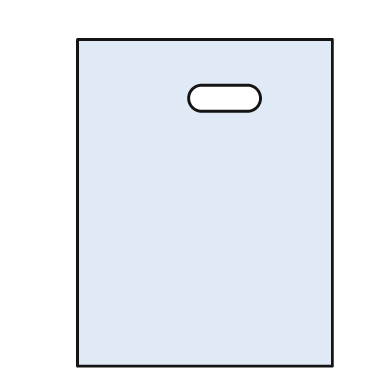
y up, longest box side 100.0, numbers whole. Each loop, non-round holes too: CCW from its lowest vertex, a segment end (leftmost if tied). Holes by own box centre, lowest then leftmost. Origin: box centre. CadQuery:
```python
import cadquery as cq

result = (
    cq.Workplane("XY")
    .moveTo(-39.0, -50.0)
    .lineTo(39.0, -50.0)
    .lineTo(39.0, 50.0)
    .lineTo(-39.0, 50.0)
    .close()
    .moveTo(-1.0, 28.0)
    .lineTo(13.0, 28.0)
    .threePointArc((17.0, 32.0), (13.0, 36.0))
    .lineTo(-1.0, 36.0)
    .threePointArc((-5.0, 32.0), (-1.0, 28.0))
    .close()
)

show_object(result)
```